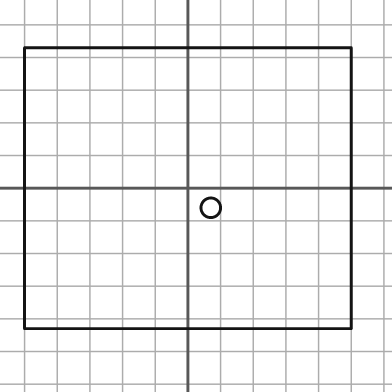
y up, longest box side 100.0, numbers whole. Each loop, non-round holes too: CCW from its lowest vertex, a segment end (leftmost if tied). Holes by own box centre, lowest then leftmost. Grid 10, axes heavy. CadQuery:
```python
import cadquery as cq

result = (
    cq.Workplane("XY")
    .moveTo(-50.0, -43.0)
    .lineTo(50.0, -43.0)
    .lineTo(50.0, 43.0)
    .lineTo(-50.0, 43.0)
    .close()
    .moveTo(7.0, -6.0)
    .circle(3.0)
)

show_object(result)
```